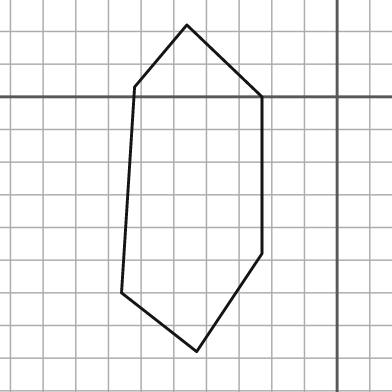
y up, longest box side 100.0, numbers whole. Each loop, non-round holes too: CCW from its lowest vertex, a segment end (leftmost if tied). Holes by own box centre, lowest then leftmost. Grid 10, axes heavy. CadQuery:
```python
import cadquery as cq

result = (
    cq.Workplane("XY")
    .moveTo(-43.0, -78.0)
    .lineTo(-23.0, -48.0)
    .lineTo(-23.0, 0.0)
    .lineTo(-46.0, 22.0)
    .lineTo(-62.0, 3.0)
    .lineTo(-66.0, -60.0)
    .close()
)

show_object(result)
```